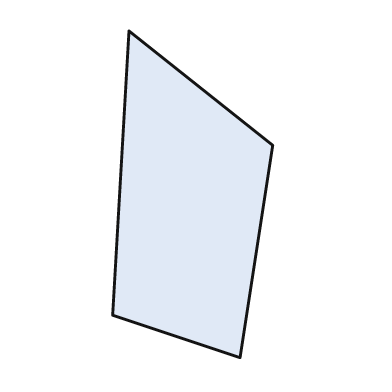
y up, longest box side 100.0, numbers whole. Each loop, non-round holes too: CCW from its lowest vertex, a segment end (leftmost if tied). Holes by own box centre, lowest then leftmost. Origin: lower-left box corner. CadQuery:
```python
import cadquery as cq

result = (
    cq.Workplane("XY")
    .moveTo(39.0, 0.0)
    .lineTo(49.0, 65.0)
    .lineTo(5.0, 100.0)
    .lineTo(0.0, 13.0)
    .close()
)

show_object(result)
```